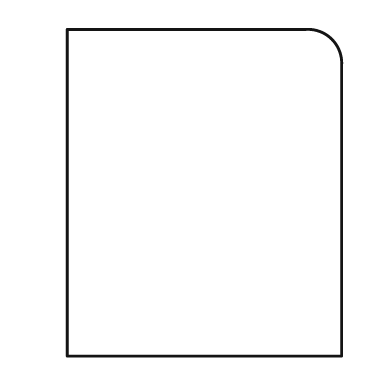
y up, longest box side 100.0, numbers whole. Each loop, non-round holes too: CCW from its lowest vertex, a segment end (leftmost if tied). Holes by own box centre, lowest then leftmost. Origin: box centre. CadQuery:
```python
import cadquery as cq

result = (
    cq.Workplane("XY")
    .moveTo(-42.0, -50.0)
    .lineTo(42.0, -50.0)
    .lineTo(42.0, 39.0)
    .threePointArc((39.0, 47.0), (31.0, 50.0))
    .lineTo(-42.0, 50.0)
    .close()
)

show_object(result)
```